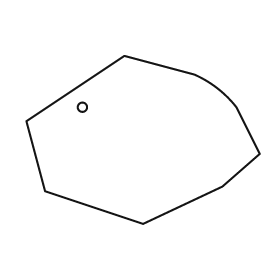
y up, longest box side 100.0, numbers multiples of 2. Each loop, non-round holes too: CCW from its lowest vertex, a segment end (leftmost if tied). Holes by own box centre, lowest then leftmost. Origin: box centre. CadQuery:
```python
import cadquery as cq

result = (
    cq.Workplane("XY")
    .moveTo(0.0, -36.0)
    .lineTo(34.0, -20.0)
    .lineTo(50.0, -6.0)
    .lineTo(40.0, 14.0)
    .threePointArc((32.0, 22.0), (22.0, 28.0))
    .lineTo(-8.0, 36.0)
    .lineTo(-50.0, 8.0)
    .lineTo(-42.0, -22.0)
    .close()
    .moveTo(-26.0, 14.0)
    .circle(2.0)
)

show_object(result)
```